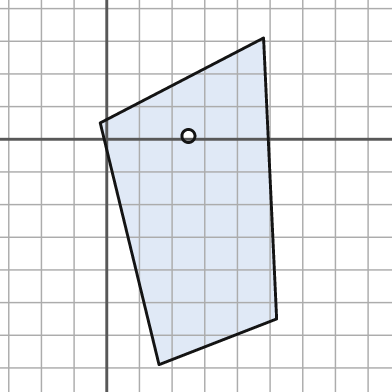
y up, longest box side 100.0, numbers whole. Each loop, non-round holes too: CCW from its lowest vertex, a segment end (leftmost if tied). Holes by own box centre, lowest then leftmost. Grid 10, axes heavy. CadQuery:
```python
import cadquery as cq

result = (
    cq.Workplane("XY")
    .moveTo(16.0, -69.0)
    .lineTo(52.0, -55.0)
    .lineTo(48.0, 31.0)
    .lineTo(-2.0, 5.0)
    .close()
    .moveTo(25.0, 1.0)
    .circle(2.0)
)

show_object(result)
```